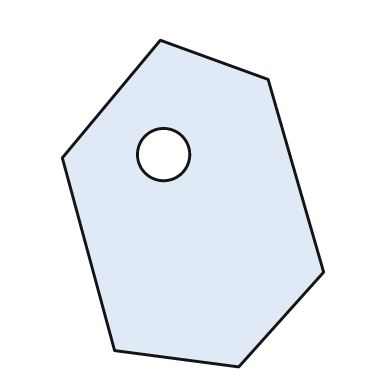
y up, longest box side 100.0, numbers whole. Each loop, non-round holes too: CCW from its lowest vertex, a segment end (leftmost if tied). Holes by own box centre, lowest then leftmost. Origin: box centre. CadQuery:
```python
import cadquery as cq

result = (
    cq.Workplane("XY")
    .moveTo(14.0, -50.0)
    .lineTo(40.0, -21.0)
    .lineTo(23.0, 38.0)
    .lineTo(-10.0, 50.0)
    .lineTo(-40.0, 14.0)
    .lineTo(-24.0, -45.0)
    .close()
    .moveTo(-9.0, 15.0)
    .circle(8.0)
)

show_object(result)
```